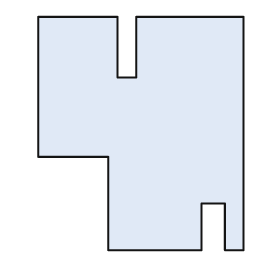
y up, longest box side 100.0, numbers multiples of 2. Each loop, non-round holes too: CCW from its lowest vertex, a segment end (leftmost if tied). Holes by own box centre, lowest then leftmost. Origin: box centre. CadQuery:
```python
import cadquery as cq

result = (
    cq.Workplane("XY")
    .moveTo(-14.0, -50.0)
    .lineTo(26.0, -50.0)
    .lineTo(26.0, -30.0)
    .lineTo(36.0, -30.0)
    .lineTo(36.0, -50.0)
    .lineTo(44.0, -50.0)
    .lineTo(44.0, 50.0)
    .lineTo(-2.0, 50.0)
    .lineTo(-2.0, 24.0)
    .lineTo(-10.0, 24.0)
    .lineTo(-10.0, 50.0)
    .lineTo(-44.0, 50.0)
    .lineTo(-44.0, -10.0)
    .lineTo(-14.0, -10.0)
    .close()
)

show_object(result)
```